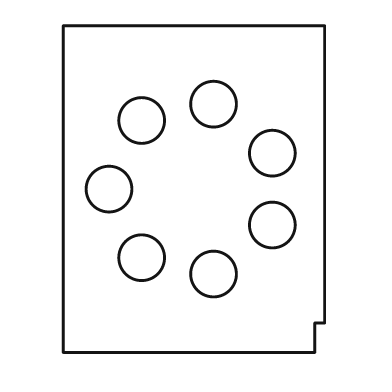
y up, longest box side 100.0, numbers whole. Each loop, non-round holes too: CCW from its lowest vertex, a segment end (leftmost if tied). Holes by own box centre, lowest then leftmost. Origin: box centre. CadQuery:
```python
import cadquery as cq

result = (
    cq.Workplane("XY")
    .moveTo(-40.0, -50.0)
    .lineTo(37.0, -50.0)
    .lineTo(37.0, -41.0)
    .lineTo(40.0, -41.0)
    .lineTo(40.0, 50.0)
    .lineTo(-40.0, 50.0)
    .close()
    .moveTo(6.0, -26.0)
    .circle(7.0)
    .moveTo(-16.0, -21.0)
    .circle(7.0)
    .moveTo(24.0, -11.0)
    .circle(7.0)
    .moveTo(-26.0, 0.0)
    .circle(7.0)
    .moveTo(24.0, 11.0)
    .circle(7.0)
    .moveTo(-16.0, 21.0)
    .circle(7.0)
    .moveTo(6.0, 26.0)
    .circle(7.0)
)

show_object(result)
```